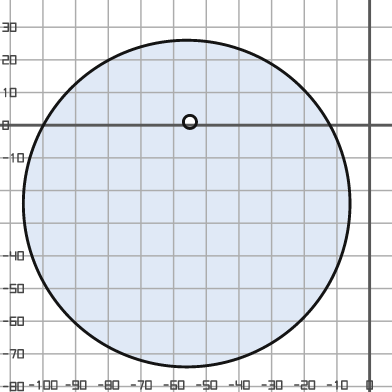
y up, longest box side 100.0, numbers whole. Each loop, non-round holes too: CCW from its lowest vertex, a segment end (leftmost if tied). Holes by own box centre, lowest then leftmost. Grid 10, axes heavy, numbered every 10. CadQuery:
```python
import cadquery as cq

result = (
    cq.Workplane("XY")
    .moveTo(-56.0, -24.0)
    .circle(50.0)
    .moveTo(-55.0, 1.0)
    .circle(2.0)
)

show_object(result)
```